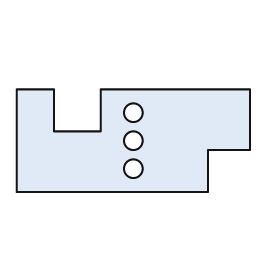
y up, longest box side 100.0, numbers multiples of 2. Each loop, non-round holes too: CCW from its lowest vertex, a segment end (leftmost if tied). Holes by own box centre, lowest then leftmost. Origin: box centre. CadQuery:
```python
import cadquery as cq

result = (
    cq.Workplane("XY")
    .moveTo(-50.0, -22.0)
    .lineTo(32.0, -22.0)
    .lineTo(32.0, -4.0)
    .lineTo(50.0, -4.0)
    .lineTo(50.0, 22.0)
    .lineTo(-14.0, 22.0)
    .lineTo(-14.0, 4.0)
    .lineTo(-34.0, 4.0)
    .lineTo(-34.0, 22.0)
    .lineTo(-50.0, 22.0)
    .close()
    .moveTo(0.0, -12.0)
    .circle(4.0)
    .moveTo(0.0, 0.0)
    .circle(4.0)
    .moveTo(0.0, 12.0)
    .circle(4.0)
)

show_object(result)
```